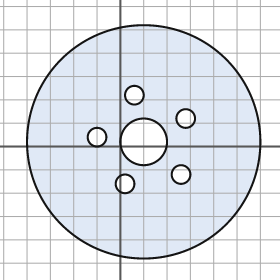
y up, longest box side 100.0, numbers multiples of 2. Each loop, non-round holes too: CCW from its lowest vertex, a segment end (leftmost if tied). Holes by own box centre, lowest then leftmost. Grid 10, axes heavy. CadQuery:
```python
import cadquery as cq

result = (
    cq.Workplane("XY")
    .moveTo(10.0, 2.0)
    .circle(50.0)
    .moveTo(2.0, -16.0)
    .circle(4.0)
    .moveTo(26.0, -12.0)
    .circle(4.0)
    .moveTo(10.0, 2.0)
    .circle(10.0)
    .moveTo(-10.0, 4.0)
    .circle(4.0)
    .moveTo(28.0, 12.0)
    .circle(4.0)
    .moveTo(6.0, 22.0)
    .circle(4.0)
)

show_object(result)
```